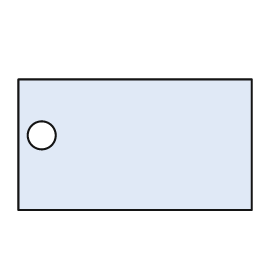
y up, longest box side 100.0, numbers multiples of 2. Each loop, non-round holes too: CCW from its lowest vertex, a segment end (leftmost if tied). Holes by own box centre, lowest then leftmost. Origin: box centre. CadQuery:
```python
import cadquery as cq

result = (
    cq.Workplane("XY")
    .moveTo(-50.0, -28.0)
    .lineTo(50.0, -28.0)
    .lineTo(50.0, 28.0)
    .lineTo(-50.0, 28.0)
    .close()
    .moveTo(-40.0, 4.0)
    .circle(6.0)
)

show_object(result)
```